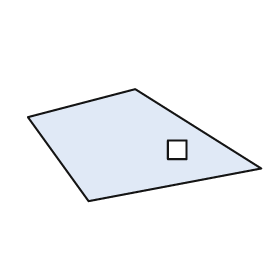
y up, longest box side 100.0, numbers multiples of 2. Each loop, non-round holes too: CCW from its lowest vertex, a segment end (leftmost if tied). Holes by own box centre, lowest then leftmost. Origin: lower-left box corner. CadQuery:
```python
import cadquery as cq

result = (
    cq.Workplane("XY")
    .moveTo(26.0, 0.0)
    .lineTo(100.0, 14.0)
    .lineTo(46.0, 48.0)
    .lineTo(0.0, 36.0)
    .close()
    .moveTo(60.0, 18.0)
    .lineTo(68.0, 18.0)
    .lineTo(68.0, 26.0)
    .lineTo(60.0, 26.0)
    .close()
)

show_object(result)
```